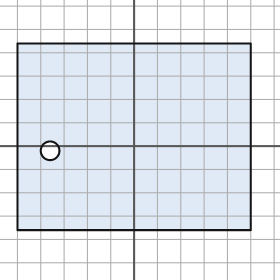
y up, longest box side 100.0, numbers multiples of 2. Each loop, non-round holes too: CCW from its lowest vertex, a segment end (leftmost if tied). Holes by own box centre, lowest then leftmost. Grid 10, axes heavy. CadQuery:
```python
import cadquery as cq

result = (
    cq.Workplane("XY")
    .moveTo(-50.0, -36.0)
    .lineTo(50.0, -36.0)
    .lineTo(50.0, 44.0)
    .lineTo(-50.0, 44.0)
    .close()
    .moveTo(-36.0, -2.0)
    .circle(4.0)
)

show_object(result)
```